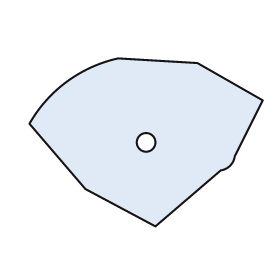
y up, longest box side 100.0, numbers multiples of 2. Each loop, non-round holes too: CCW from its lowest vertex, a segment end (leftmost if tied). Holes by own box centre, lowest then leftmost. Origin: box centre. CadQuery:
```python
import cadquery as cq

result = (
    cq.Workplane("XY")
    .moveTo(4.0, -36.0)
    .lineTo(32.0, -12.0)
    .threePointArc((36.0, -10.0), (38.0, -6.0))
    .lineTo(50.0, 18.0)
    .lineTo(22.0, 34.0)
    .lineTo(-12.0, 36.0)
    .threePointArc((-34.0, 26.0), (-50.0, 8.0))
    .lineTo(-26.0, -20.0)
    .close()
    .moveTo(0.0, 0.0)
    .circle(4.0)
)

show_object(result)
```